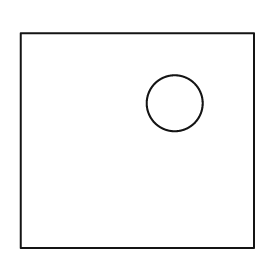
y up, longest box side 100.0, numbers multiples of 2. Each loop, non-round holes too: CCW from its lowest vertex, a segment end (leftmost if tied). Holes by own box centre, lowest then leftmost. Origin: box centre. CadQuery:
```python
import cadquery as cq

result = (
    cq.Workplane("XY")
    .moveTo(-50.0, -46.0)
    .lineTo(50.0, -46.0)
    .lineTo(50.0, 46.0)
    .lineTo(-50.0, 46.0)
    .close()
    .moveTo(16.0, 16.0)
    .circle(12.0)
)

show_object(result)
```